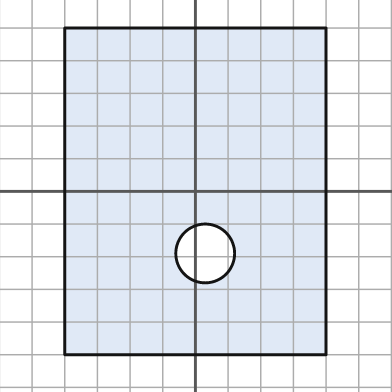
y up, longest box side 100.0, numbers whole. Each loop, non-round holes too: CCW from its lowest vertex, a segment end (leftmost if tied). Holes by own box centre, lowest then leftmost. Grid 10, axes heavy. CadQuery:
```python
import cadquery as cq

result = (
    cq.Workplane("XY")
    .moveTo(-40.0, -50.0)
    .lineTo(40.0, -50.0)
    .lineTo(40.0, 50.0)
    .lineTo(-40.0, 50.0)
    .close()
    .moveTo(3.0, -19.0)
    .circle(9.0)
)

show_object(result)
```